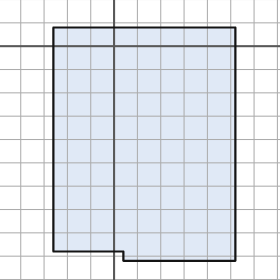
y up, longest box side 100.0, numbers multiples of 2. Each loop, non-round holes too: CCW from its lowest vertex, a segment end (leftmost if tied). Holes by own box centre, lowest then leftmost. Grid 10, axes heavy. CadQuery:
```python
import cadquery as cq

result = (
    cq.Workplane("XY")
    .moveTo(4.0, -92.0)
    .lineTo(52.0, -92.0)
    .lineTo(52.0, 8.0)
    .lineTo(-26.0, 8.0)
    .lineTo(-26.0, -88.0)
    .lineTo(4.0, -88.0)
    .close()
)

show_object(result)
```